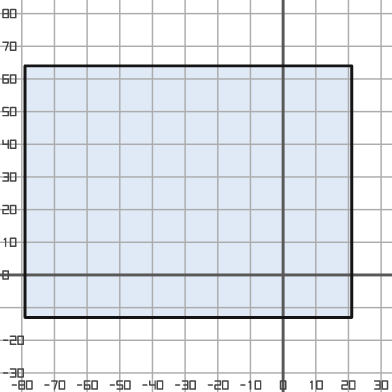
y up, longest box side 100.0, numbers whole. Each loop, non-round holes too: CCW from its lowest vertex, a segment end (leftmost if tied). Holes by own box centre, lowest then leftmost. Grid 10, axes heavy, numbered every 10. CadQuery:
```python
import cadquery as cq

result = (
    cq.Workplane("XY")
    .moveTo(-79.0, -13.0)
    .lineTo(21.0, -13.0)
    .lineTo(21.0, 64.0)
    .lineTo(-79.0, 64.0)
    .close()
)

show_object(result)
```